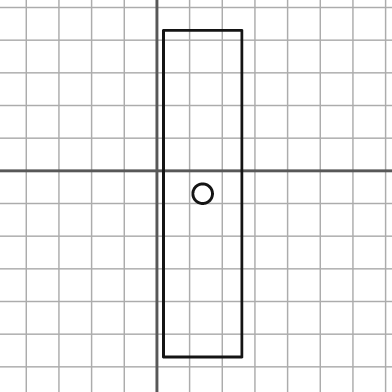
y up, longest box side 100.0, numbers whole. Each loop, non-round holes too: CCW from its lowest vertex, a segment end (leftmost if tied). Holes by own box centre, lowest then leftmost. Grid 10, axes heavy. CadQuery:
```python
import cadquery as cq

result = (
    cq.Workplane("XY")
    .moveTo(2.0, -57.0)
    .lineTo(26.0, -57.0)
    .lineTo(26.0, 43.0)
    .lineTo(2.0, 43.0)
    .close()
    .moveTo(14.0, -7.0)
    .circle(3.0)
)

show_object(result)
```